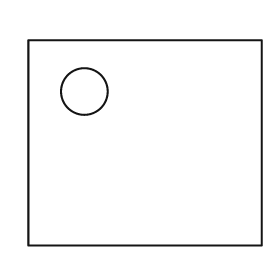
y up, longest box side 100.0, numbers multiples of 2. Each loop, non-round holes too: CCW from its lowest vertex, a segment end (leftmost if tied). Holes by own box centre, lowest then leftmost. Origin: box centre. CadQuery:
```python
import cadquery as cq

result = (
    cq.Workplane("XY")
    .moveTo(-50.0, -44.0)
    .lineTo(50.0, -44.0)
    .lineTo(50.0, 44.0)
    .lineTo(-50.0, 44.0)
    .close()
    .moveTo(-26.0, 22.0)
    .circle(10.0)
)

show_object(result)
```